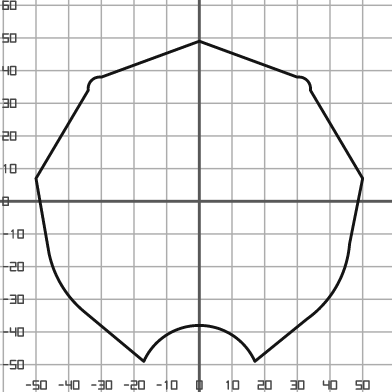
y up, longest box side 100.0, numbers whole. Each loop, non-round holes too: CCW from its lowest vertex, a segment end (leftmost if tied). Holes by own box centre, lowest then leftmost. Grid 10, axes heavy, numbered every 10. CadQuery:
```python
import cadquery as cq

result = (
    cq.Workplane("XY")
    .moveTo(-17.0, -49.0)
    .threePointArc((0.0, -38.0), (17.0, -49.0))
    .lineTo(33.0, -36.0)
    .threePointArc((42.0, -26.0), (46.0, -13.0))
    .lineTo(50.0, 7.0)
    .lineTo(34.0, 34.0)
    .threePointArc((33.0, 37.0), (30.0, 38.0))
    .lineTo(0.0, 49.0)
    .lineTo(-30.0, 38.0)
    .threePointArc((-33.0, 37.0), (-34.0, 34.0))
    .lineTo(-50.0, 7.0)
    .lineTo(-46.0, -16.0)
    .threePointArc((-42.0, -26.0), (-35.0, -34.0))
    .close()
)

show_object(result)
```